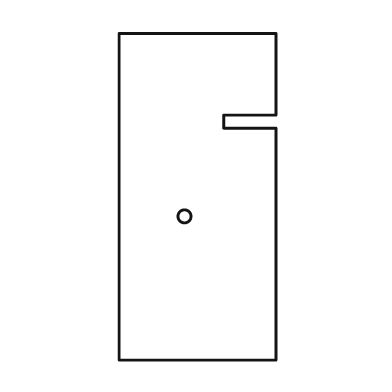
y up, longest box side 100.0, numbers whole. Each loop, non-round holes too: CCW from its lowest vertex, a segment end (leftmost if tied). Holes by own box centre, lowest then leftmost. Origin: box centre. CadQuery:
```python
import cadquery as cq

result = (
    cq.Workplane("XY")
    .moveTo(-24.0, -50.0)
    .lineTo(24.0, -50.0)
    .lineTo(24.0, 21.0)
    .lineTo(8.0, 21.0)
    .lineTo(8.0, 25.0)
    .lineTo(24.0, 25.0)
    .lineTo(24.0, 50.0)
    .lineTo(-24.0, 50.0)
    .close()
    .moveTo(-4.0, -6.0)
    .circle(2.0)
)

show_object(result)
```